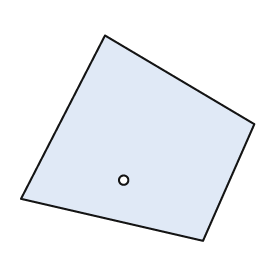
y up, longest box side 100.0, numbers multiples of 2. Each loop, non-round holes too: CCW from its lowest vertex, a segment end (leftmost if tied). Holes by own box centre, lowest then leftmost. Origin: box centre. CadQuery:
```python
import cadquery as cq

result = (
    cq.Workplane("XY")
    .moveTo(28.0, -44.0)
    .lineTo(50.0, 6.0)
    .lineTo(-14.0, 44.0)
    .lineTo(-50.0, -26.0)
    .close()
    .moveTo(-6.0, -18.0)
    .circle(2.0)
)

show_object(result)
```